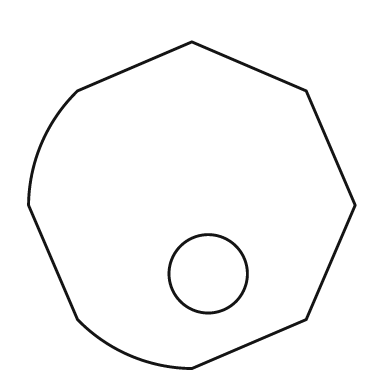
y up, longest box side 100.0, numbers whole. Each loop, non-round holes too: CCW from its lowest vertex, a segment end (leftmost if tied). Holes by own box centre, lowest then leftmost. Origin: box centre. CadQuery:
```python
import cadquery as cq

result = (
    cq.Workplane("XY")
    .moveTo(0.0, -50.0)
    .lineTo(35.0, -35.0)
    .lineTo(50.0, 0.0)
    .lineTo(35.0, 35.0)
    .lineTo(0.0, 50.0)
    .lineTo(-35.0, 35.0)
    .threePointArc((-46.0, 19.0), (-50.0, 0.0))
    .lineTo(-35.0, -35.0)
    .threePointArc((-19.0, -46.0), (0.0, -50.0))
    .close()
    .moveTo(5.0, -21.0)
    .circle(12.0)
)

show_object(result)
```